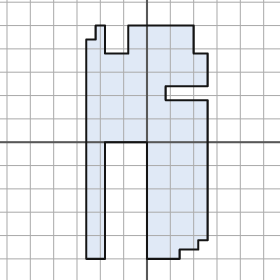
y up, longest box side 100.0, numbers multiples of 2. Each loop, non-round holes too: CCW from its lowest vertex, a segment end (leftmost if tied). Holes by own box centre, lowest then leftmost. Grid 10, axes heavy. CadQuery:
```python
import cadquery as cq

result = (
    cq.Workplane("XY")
    .moveTo(-26.0, -50.0)
    .lineTo(-18.0, -50.0)
    .lineTo(-18.0, 0.0)
    .lineTo(0.0, 0.0)
    .lineTo(0.0, -50.0)
    .lineTo(14.0, -50.0)
    .lineTo(14.0, -46.0)
    .lineTo(22.0, -46.0)
    .lineTo(22.0, -42.0)
    .lineTo(26.0, -42.0)
    .lineTo(26.0, 18.0)
    .lineTo(8.0, 18.0)
    .lineTo(8.0, 24.0)
    .lineTo(26.0, 24.0)
    .lineTo(26.0, 38.0)
    .lineTo(20.0, 38.0)
    .lineTo(20.0, 50.0)
    .lineTo(-8.0, 50.0)
    .lineTo(-8.0, 38.0)
    .lineTo(-18.0, 38.0)
    .lineTo(-18.0, 50.0)
    .lineTo(-22.0, 50.0)
    .lineTo(-22.0, 44.0)
    .lineTo(-26.0, 44.0)
    .close()
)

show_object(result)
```